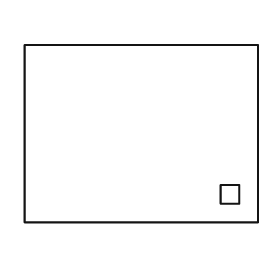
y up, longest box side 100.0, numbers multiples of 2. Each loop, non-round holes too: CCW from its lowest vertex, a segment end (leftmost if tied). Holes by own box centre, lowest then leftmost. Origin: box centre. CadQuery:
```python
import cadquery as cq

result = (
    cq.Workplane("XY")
    .moveTo(-50.0, -38.0)
    .lineTo(50.0, -38.0)
    .lineTo(50.0, 38.0)
    .lineTo(-50.0, 38.0)
    .close()
    .moveTo(34.0, -30.0)
    .lineTo(42.0, -30.0)
    .lineTo(42.0, -22.0)
    .lineTo(34.0, -22.0)
    .close()
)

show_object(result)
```